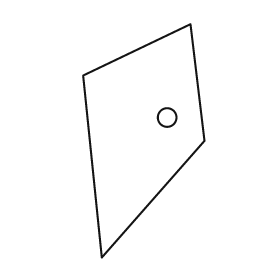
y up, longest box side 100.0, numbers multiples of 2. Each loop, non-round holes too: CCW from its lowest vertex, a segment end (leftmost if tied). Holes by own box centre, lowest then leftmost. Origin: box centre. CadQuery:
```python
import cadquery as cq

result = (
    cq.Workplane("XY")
    .moveTo(-18.0, -50.0)
    .lineTo(26.0, 0.0)
    .lineTo(20.0, 50.0)
    .lineTo(-26.0, 28.0)
    .close()
    .moveTo(10.0, 10.0)
    .circle(4.0)
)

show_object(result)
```